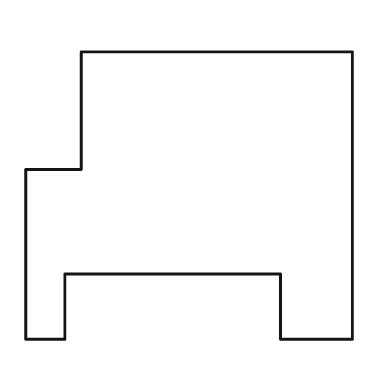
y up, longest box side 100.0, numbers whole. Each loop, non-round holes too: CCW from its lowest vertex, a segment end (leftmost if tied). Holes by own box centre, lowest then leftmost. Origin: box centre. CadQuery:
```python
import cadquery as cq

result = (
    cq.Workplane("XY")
    .moveTo(-50.0, -44.0)
    .lineTo(-38.0, -44.0)
    .lineTo(-38.0, -24.0)
    .lineTo(28.0, -24.0)
    .lineTo(28.0, -44.0)
    .lineTo(50.0, -44.0)
    .lineTo(50.0, 44.0)
    .lineTo(-33.0, 44.0)
    .lineTo(-33.0, 8.0)
    .lineTo(-50.0, 8.0)
    .close()
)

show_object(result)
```